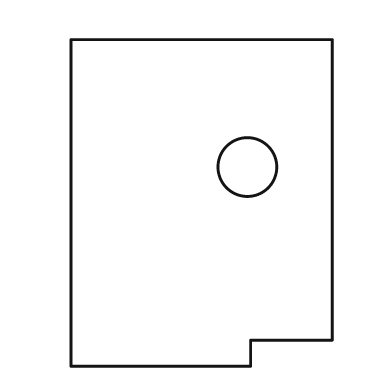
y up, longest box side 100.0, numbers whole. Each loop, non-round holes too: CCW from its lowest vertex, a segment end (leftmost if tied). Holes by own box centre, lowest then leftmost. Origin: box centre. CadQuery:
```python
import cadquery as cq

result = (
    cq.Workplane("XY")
    .moveTo(-40.0, -50.0)
    .lineTo(15.0, -50.0)
    .lineTo(15.0, -42.0)
    .lineTo(40.0, -42.0)
    .lineTo(40.0, 50.0)
    .lineTo(-40.0, 50.0)
    .close()
    .moveTo(14.0, 11.0)
    .circle(9.0)
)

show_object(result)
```